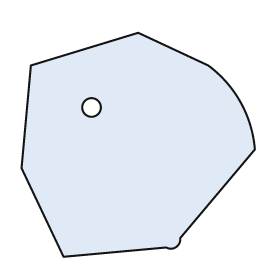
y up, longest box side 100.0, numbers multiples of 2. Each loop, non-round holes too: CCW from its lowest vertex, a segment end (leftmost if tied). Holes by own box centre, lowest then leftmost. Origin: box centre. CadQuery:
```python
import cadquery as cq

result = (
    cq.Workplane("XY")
    .moveTo(-32.0, -48.0)
    .lineTo(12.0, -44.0)
    .threePointArc((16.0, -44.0), (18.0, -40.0))
    .lineTo(50.0, -2.0)
    .threePointArc((44.0, 18.0), (30.0, 34.0))
    .lineTo(0.0, 48.0)
    .lineTo(-46.0, 34.0)
    .lineTo(-50.0, -10.0)
    .close()
    .moveTo(-20.0, 16.0)
    .circle(4.0)
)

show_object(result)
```